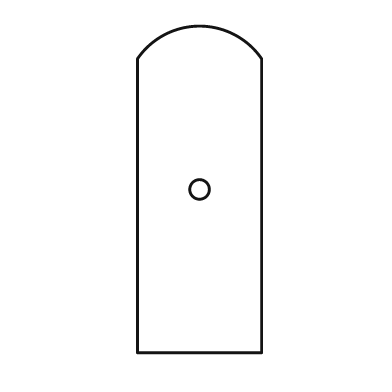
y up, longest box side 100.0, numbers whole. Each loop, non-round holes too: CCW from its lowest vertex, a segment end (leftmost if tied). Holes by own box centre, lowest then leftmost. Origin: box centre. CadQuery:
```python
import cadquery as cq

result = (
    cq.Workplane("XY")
    .moveTo(-19.0, -50.0)
    .lineTo(19.0, -50.0)
    .lineTo(19.0, 40.0)
    .threePointArc((0.0, 50.0), (-19.0, 40.0))
    .close()
    .moveTo(0.0, 0.0)
    .circle(3.0)
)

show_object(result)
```